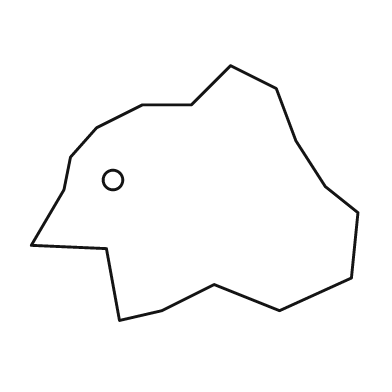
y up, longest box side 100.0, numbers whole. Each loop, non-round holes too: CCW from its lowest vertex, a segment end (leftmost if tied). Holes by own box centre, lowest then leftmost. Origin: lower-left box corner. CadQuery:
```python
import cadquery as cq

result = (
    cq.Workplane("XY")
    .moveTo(27.0, 0.0)
    .lineTo(40.0, 3.0)
    .lineTo(56.0, 11.0)
    .lineTo(76.0, 3.0)
    .lineTo(98.0, 13.0)
    .lineTo(100.0, 33.0)
    .lineTo(90.0, 41.0)
    .lineTo(81.0, 55.0)
    .lineTo(75.0, 71.0)
    .lineTo(61.0, 78.0)
    .lineTo(49.0, 66.0)
    .lineTo(34.0, 66.0)
    .lineTo(20.0, 59.0)
    .lineTo(12.0, 50.0)
    .lineTo(10.0, 40.0)
    .lineTo(0.0, 23.0)
    .lineTo(23.0, 22.0)
    .close()
    .moveTo(25.0, 43.0)
    .circle(3.0)
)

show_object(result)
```